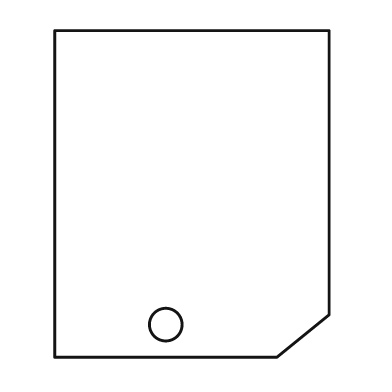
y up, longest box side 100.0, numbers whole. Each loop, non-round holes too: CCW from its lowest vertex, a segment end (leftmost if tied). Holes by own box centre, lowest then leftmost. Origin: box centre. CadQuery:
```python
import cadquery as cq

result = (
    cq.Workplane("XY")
    .moveTo(-42.0, -50.0)
    .lineTo(26.0, -50.0)
    .lineTo(42.0, -37.0)
    .lineTo(42.0, 50.0)
    .lineTo(-42.0, 50.0)
    .close()
    .moveTo(-8.0, -40.0)
    .circle(5.0)
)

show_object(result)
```